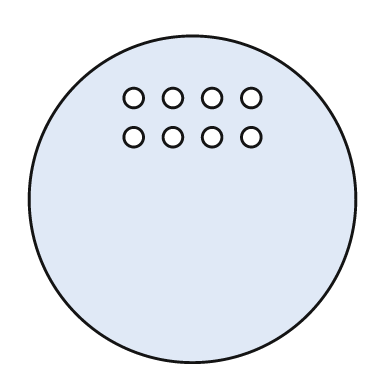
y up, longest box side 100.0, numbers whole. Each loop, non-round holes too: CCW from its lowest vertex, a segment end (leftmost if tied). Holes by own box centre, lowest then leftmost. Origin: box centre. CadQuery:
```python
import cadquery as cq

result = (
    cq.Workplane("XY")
    .moveTo(0.0, 0.0)
    .circle(50.0)
    .moveTo(-18.0, 19.0)
    .circle(3.0)
    .moveTo(-6.0, 19.0)
    .circle(3.0)
    .moveTo(6.0, 19.0)
    .circle(3.0)
    .moveTo(18.0, 19.0)
    .circle(3.0)
    .moveTo(-18.0, 31.0)
    .circle(3.0)
    .moveTo(-6.0, 31.0)
    .circle(3.0)
    .moveTo(6.0, 31.0)
    .circle(3.0)
    .moveTo(18.0, 31.0)
    .circle(3.0)
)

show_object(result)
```